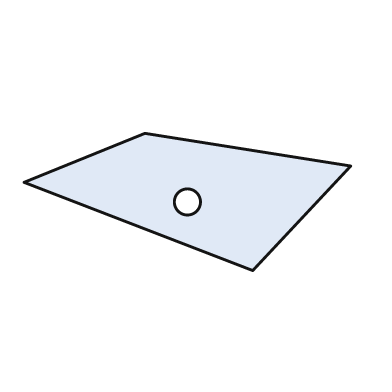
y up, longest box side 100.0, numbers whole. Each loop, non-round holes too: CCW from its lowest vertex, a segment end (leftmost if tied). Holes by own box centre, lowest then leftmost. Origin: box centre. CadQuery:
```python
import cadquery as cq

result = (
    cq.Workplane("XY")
    .moveTo(20.0, -21.0)
    .lineTo(50.0, 11.0)
    .lineTo(-13.0, 21.0)
    .lineTo(-50.0, 6.0)
    .close()
    .moveTo(0.0, 0.0)
    .circle(4.0)
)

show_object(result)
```